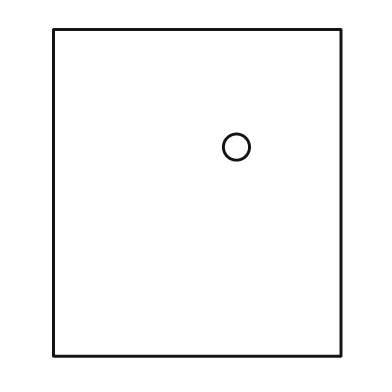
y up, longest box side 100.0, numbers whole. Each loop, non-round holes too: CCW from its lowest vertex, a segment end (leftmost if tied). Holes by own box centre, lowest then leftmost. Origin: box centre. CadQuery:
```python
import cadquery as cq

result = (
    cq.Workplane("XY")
    .moveTo(-44.0, -50.0)
    .lineTo(44.0, -50.0)
    .lineTo(44.0, 50.0)
    .lineTo(-44.0, 50.0)
    .close()
    .moveTo(12.0, 14.0)
    .circle(4.0)
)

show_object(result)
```